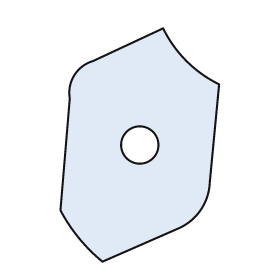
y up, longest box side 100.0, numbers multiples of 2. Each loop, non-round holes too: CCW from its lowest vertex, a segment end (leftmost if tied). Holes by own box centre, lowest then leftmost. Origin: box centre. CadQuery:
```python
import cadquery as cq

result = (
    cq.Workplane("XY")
    .moveTo(-16.0, -50.0)
    .lineTo(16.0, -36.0)
    .threePointArc((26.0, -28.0), (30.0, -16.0))
    .lineTo(34.0, 26.0)
    .threePointArc((20.0, 36.0), (10.0, 50.0))
    .lineTo(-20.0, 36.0)
    .threePointArc((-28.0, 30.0), (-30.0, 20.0))
    .lineTo(-34.0, -28.0)
    .threePointArc((-26.0, -40.0), (-16.0, -50.0))
    .close()
    .moveTo(0.0, 0.0)
    .circle(8.0)
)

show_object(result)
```